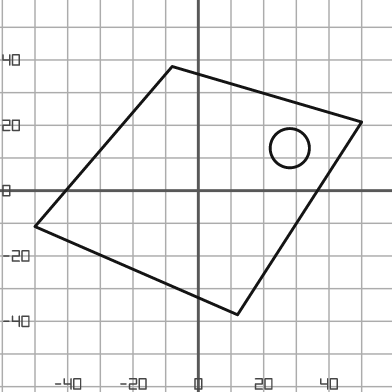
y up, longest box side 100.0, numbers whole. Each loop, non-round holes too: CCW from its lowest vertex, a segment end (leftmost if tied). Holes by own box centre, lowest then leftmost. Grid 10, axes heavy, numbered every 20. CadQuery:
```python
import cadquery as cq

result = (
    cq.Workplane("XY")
    .moveTo(12.0, -38.0)
    .lineTo(50.0, 21.0)
    .lineTo(-8.0, 38.0)
    .lineTo(-50.0, -11.0)
    .close()
    .moveTo(28.0, 13.0)
    .circle(6.0)
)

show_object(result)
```